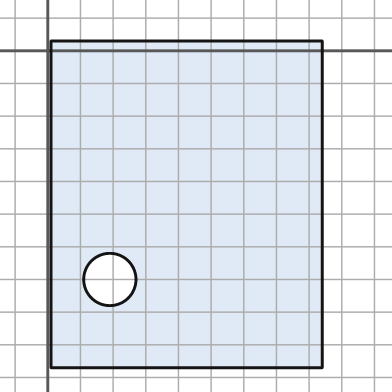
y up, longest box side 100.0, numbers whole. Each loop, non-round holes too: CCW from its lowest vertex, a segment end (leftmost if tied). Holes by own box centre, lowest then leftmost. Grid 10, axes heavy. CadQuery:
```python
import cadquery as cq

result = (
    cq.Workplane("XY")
    .moveTo(1.0, -97.0)
    .lineTo(84.0, -97.0)
    .lineTo(84.0, 3.0)
    .lineTo(1.0, 3.0)
    .close()
    .moveTo(19.0, -70.0)
    .circle(8.0)
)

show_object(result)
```